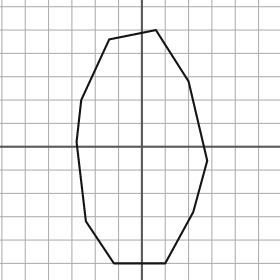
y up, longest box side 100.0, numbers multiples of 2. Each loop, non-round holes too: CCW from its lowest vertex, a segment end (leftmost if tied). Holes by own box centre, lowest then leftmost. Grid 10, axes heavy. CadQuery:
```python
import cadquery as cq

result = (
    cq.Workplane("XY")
    .moveTo(-12.0, -50.0)
    .lineTo(10.0, -50.0)
    .lineTo(22.0, -28.0)
    .lineTo(28.0, -6.0)
    .lineTo(20.0, 28.0)
    .lineTo(6.0, 50.0)
    .lineTo(-14.0, 46.0)
    .lineTo(-26.0, 20.0)
    .lineTo(-28.0, 2.0)
    .lineTo(-24.0, -32.0)
    .close()
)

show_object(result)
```